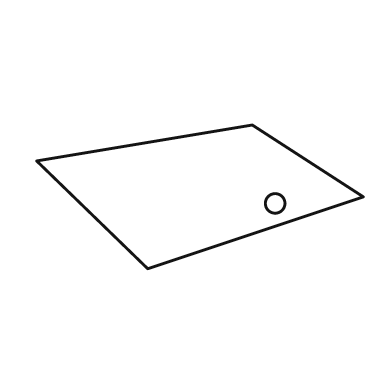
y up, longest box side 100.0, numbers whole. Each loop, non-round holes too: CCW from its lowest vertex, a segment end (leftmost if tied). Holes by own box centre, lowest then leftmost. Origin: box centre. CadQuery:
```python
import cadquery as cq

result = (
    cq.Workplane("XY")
    .moveTo(-16.0, -22.0)
    .lineTo(50.0, 0.0)
    .lineTo(16.0, 22.0)
    .lineTo(-50.0, 11.0)
    .close()
    .moveTo(23.0, -2.0)
    .circle(3.0)
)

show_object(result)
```